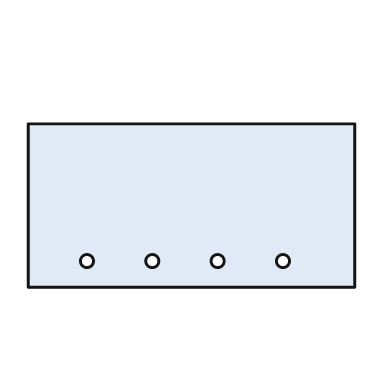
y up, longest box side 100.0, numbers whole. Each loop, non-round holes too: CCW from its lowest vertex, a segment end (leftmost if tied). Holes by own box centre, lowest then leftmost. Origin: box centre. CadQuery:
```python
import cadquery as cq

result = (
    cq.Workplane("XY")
    .moveTo(-50.0, -25.0)
    .lineTo(50.0, -25.0)
    .lineTo(50.0, 25.0)
    .lineTo(-50.0, 25.0)
    .close()
    .moveTo(-32.0, -17.0)
    .circle(2.0)
    .moveTo(-12.0, -17.0)
    .circle(2.0)
    .moveTo(8.0, -17.0)
    .circle(2.0)
    .moveTo(28.0, -17.0)
    .circle(2.0)
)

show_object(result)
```